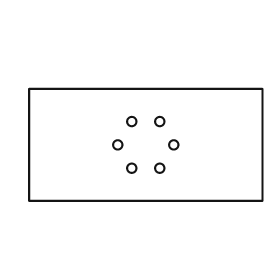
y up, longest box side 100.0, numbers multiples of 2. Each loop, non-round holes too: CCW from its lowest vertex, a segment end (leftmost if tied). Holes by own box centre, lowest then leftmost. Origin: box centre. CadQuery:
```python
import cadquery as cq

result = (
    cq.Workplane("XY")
    .moveTo(-50.0, -24.0)
    .lineTo(50.0, -24.0)
    .lineTo(50.0, 24.0)
    .lineTo(-50.0, 24.0)
    .close()
    .moveTo(-6.0, -10.0)
    .circle(2.0)
    .moveTo(6.0, -10.0)
    .circle(2.0)
    .moveTo(-12.0, 0.0)
    .circle(2.0)
    .moveTo(12.0, 0.0)
    .circle(2.0)
    .moveTo(-6.0, 10.0)
    .circle(2.0)
    .moveTo(6.0, 10.0)
    .circle(2.0)
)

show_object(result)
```